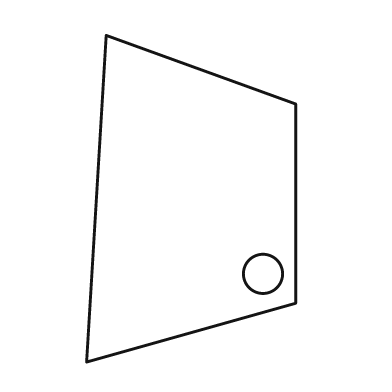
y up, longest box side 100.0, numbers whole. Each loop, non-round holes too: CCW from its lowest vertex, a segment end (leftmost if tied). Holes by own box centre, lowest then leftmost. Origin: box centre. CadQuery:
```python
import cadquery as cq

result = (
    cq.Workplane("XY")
    .moveTo(-32.0, -50.0)
    .lineTo(32.0, -32.0)
    .lineTo(32.0, 29.0)
    .lineTo(-26.0, 50.0)
    .close()
    .moveTo(22.0, -23.0)
    .circle(6.0)
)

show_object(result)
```